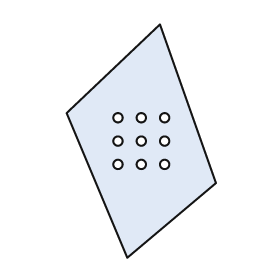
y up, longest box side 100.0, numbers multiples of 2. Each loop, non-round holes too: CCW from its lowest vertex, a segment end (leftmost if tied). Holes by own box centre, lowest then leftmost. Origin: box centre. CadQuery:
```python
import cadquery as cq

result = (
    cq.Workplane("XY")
    .moveTo(-6.0, -50.0)
    .lineTo(32.0, -18.0)
    .lineTo(8.0, 50.0)
    .lineTo(-32.0, 12.0)
    .close()
    .moveTo(-10.0, -10.0)
    .circle(2.0)
    .moveTo(0.0, -10.0)
    .circle(2.0)
    .moveTo(10.0, -10.0)
    .circle(2.0)
    .moveTo(-10.0, 0.0)
    .circle(2.0)
    .moveTo(0.0, 0.0)
    .circle(2.0)
    .moveTo(10.0, 0.0)
    .circle(2.0)
    .moveTo(-10.0, 10.0)
    .circle(2.0)
    .moveTo(0.0, 10.0)
    .circle(2.0)
    .moveTo(10.0, 10.0)
    .circle(2.0)
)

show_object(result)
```